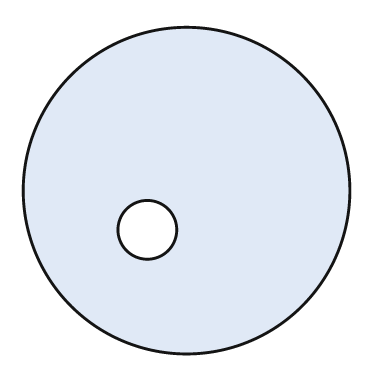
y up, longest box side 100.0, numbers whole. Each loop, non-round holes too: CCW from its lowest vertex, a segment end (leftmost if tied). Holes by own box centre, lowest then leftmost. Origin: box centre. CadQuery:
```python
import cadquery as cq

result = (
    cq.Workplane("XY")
    .moveTo(0.0, 0.0)
    .circle(50.0)
    .moveTo(-12.0, -12.0)
    .circle(9.0)
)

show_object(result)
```